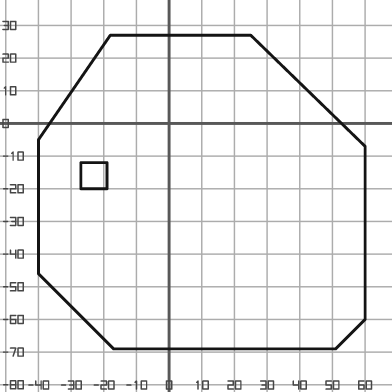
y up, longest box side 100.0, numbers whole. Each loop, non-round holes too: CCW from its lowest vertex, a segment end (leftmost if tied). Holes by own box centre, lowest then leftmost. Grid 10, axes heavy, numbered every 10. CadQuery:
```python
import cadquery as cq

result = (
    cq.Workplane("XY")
    .moveTo(-17.0, -69.0)
    .lineTo(51.0, -69.0)
    .lineTo(60.0, -60.0)
    .lineTo(60.0, -7.0)
    .lineTo(25.0, 27.0)
    .lineTo(-18.0, 27.0)
    .lineTo(-40.0, -5.0)
    .lineTo(-40.0, -46.0)
    .close()
    .moveTo(-27.0, -20.0)
    .lineTo(-19.0, -20.0)
    .lineTo(-19.0, -12.0)
    .lineTo(-27.0, -12.0)
    .close()
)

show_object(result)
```